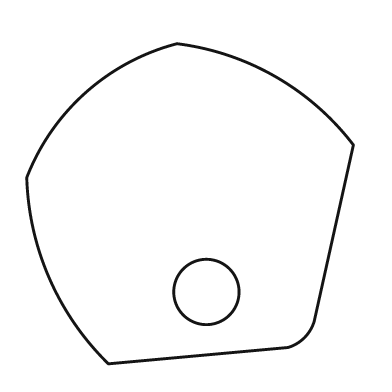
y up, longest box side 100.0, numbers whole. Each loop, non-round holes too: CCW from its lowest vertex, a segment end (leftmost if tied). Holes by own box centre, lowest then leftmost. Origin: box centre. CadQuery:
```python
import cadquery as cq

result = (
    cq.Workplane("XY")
    .moveTo(-25.0, -49.0)
    .lineTo(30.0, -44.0)
    .threePointArc((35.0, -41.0), (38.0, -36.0))
    .lineTo(50.0, 18.0)
    .threePointArc((26.0, 39.0), (-4.0, 49.0))
    .threePointArc((-32.0, 34.0), (-50.0, 8.0))
    .threePointArc((-43.0, -23.0), (-25.0, -49.0))
    .close()
    .moveTo(5.0, -27.0)
    .circle(10.0)
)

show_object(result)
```